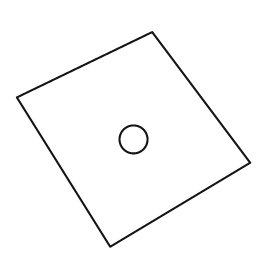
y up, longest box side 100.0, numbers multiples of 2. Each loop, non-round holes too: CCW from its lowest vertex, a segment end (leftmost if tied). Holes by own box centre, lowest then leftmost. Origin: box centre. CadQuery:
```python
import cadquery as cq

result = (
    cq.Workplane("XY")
    .moveTo(-10.0, -46.0)
    .lineTo(50.0, -10.0)
    .lineTo(8.0, 46.0)
    .lineTo(-50.0, 18.0)
    .close()
    .moveTo(0.0, 0.0)
    .circle(6.0)
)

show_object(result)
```